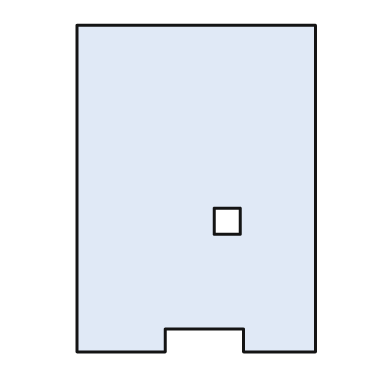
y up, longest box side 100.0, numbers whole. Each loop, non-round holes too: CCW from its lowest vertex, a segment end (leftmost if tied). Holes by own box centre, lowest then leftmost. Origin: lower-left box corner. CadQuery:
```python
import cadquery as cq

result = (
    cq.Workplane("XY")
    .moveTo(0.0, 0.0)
    .lineTo(27.0, 0.0)
    .lineTo(27.0, 7.0)
    .lineTo(51.0, 7.0)
    .lineTo(51.0, 0.0)
    .lineTo(73.0, 0.0)
    .lineTo(73.0, 100.0)
    .lineTo(0.0, 100.0)
    .close()
    .moveTo(42.0, 36.0)
    .lineTo(50.0, 36.0)
    .lineTo(50.0, 44.0)
    .lineTo(42.0, 44.0)
    .close()
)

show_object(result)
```